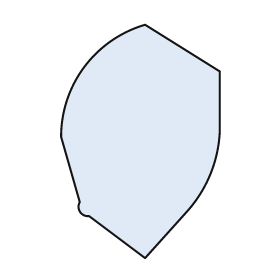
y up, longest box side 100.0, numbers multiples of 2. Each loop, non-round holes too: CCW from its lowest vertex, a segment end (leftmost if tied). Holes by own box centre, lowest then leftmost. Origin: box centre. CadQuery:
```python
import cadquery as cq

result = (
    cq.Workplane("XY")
    .moveTo(2.0, -50.0)
    .lineTo(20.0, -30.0)
    .threePointArc((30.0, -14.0), (34.0, 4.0))
    .lineTo(34.0, 30.0)
    .lineTo(2.0, 50.0)
    .threePointArc((-24.0, 32.0), (-34.0, 2.0))
    .lineTo(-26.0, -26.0)
    .threePointArc((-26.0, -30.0), (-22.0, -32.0))
    .close()
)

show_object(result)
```